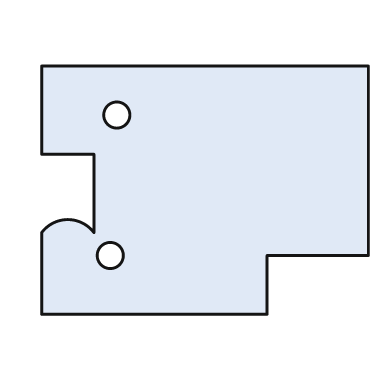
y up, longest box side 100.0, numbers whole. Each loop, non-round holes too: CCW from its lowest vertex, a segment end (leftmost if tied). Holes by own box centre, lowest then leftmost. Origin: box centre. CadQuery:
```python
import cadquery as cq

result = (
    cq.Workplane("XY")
    .moveTo(-50.0, -38.0)
    .lineTo(19.0, -38.0)
    .lineTo(19.0, -20.0)
    .lineTo(50.0, -20.0)
    .lineTo(50.0, 38.0)
    .lineTo(-50.0, 38.0)
    .lineTo(-50.0, 11.0)
    .lineTo(-34.0, 11.0)
    .lineTo(-34.0, -13.0)
    .threePointArc((-42.0, -9.0), (-50.0, -13.0))
    .close()
    .moveTo(-29.0, -20.0)
    .circle(4.0)
    .moveTo(-27.0, 23.0)
    .circle(4.0)
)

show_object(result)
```